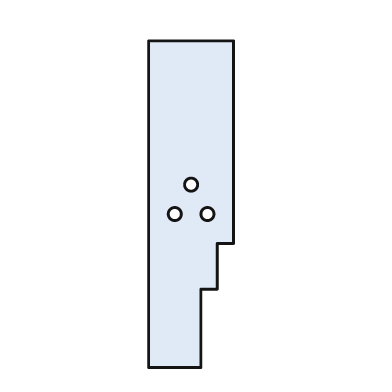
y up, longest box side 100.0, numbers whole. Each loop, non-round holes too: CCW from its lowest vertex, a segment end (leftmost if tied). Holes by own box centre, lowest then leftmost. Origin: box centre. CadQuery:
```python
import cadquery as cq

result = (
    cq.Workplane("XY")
    .moveTo(-13.0, -50.0)
    .lineTo(3.0, -50.0)
    .lineTo(3.0, -26.0)
    .lineTo(8.0, -26.0)
    .lineTo(8.0, -12.0)
    .lineTo(13.0, -12.0)
    .lineTo(13.0, 50.0)
    .lineTo(-13.0, 50.0)
    .close()
    .moveTo(-5.0, -3.0)
    .circle(2.0)
    .moveTo(5.0, -3.0)
    .circle(2.0)
    .moveTo(0.0, 6.0)
    .circle(2.0)
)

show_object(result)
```